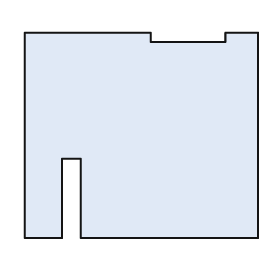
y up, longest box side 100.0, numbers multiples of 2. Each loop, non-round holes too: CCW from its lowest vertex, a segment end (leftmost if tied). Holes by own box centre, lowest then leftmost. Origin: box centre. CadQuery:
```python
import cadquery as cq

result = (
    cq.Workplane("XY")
    .moveTo(-50.0, -44.0)
    .lineTo(-34.0, -44.0)
    .lineTo(-34.0, -10.0)
    .lineTo(-26.0, -10.0)
    .lineTo(-26.0, -44.0)
    .lineTo(50.0, -44.0)
    .lineTo(50.0, 44.0)
    .lineTo(36.0, 44.0)
    .lineTo(36.0, 40.0)
    .lineTo(4.0, 40.0)
    .lineTo(4.0, 44.0)
    .lineTo(-50.0, 44.0)
    .close()
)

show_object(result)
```